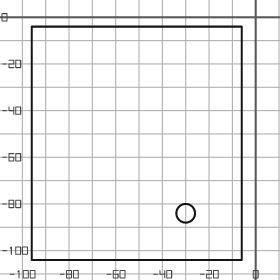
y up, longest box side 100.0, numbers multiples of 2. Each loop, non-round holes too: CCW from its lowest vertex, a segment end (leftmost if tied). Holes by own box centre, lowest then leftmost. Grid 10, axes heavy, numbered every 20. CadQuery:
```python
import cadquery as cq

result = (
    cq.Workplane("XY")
    .moveTo(-96.0, -104.0)
    .lineTo(-6.0, -104.0)
    .lineTo(-6.0, -4.0)
    .lineTo(-96.0, -4.0)
    .close()
    .moveTo(-30.0, -84.0)
    .circle(4.0)
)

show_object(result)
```